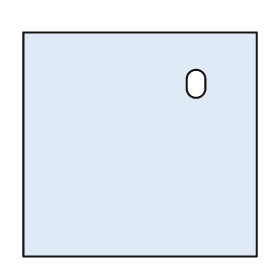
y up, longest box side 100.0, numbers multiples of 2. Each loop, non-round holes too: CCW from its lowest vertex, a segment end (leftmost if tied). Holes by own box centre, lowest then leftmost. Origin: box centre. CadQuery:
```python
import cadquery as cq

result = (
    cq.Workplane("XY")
    .moveTo(-50.0, -48.0)
    .lineTo(50.0, -48.0)
    .lineTo(50.0, 48.0)
    .lineTo(-50.0, 48.0)
    .close()
    .moveTo(20.0, 24.0)
    .threePointArc((24.0, 20.0), (28.0, 24.0))
    .lineTo(28.0, 28.0)
    .threePointArc((24.0, 32.0), (20.0, 28.0))
    .close()
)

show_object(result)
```